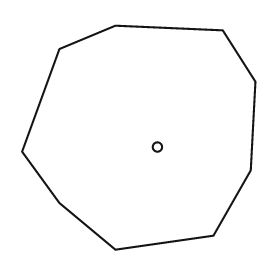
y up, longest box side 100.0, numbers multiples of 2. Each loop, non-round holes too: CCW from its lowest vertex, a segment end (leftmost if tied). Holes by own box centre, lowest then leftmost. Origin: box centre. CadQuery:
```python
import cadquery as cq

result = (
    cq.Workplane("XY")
    .moveTo(-10.0, -48.0)
    .lineTo(32.0, -42.0)
    .lineTo(48.0, -14.0)
    .lineTo(50.0, 24.0)
    .lineTo(36.0, 46.0)
    .lineTo(-10.0, 48.0)
    .lineTo(-34.0, 38.0)
    .lineTo(-50.0, -6.0)
    .lineTo(-34.0, -28.0)
    .close()
    .moveTo(8.0, -4.0)
    .circle(2.0)
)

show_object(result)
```